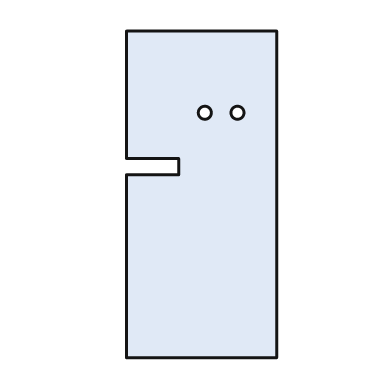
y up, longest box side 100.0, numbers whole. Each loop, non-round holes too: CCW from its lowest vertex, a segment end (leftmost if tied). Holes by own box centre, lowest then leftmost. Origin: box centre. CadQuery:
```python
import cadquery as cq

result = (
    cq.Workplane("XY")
    .moveTo(-23.0, -50.0)
    .lineTo(23.0, -50.0)
    .lineTo(23.0, 50.0)
    .lineTo(-23.0, 50.0)
    .lineTo(-23.0, 11.0)
    .lineTo(-7.0, 11.0)
    .lineTo(-7.0, 6.0)
    .lineTo(-23.0, 6.0)
    .close()
    .moveTo(1.0, 25.0)
    .circle(2.0)
    .moveTo(11.0, 25.0)
    .circle(2.0)
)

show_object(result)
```